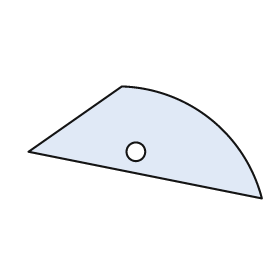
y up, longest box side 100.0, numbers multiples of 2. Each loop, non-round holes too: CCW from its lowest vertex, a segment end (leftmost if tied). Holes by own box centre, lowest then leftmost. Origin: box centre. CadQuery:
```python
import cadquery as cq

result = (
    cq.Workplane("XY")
    .moveTo(50.0, -24.0)
    .threePointArc((28.0, 10.0), (-10.0, 24.0))
    .lineTo(-50.0, -4.0)
    .close()
    .moveTo(-4.0, -4.0)
    .circle(4.0)
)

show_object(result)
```